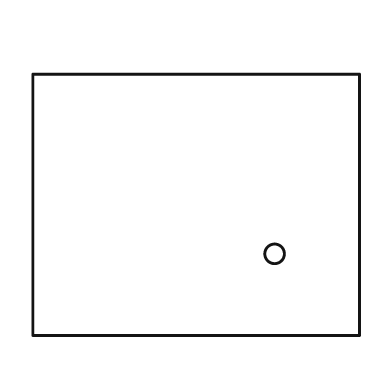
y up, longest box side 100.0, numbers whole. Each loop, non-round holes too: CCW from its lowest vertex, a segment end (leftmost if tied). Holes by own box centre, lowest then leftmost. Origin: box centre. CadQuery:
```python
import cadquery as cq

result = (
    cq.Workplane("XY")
    .moveTo(-50.0, -40.0)
    .lineTo(50.0, -40.0)
    .lineTo(50.0, 40.0)
    .lineTo(-50.0, 40.0)
    .close()
    .moveTo(24.0, -15.0)
    .circle(3.0)
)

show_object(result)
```